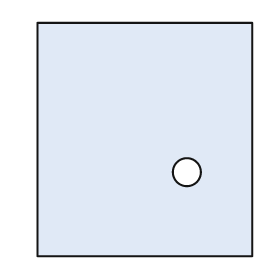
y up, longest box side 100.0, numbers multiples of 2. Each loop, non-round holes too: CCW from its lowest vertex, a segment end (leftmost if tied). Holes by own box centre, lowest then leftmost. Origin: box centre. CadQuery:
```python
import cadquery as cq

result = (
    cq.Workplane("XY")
    .moveTo(-46.0, -50.0)
    .lineTo(46.0, -50.0)
    .lineTo(46.0, 50.0)
    .lineTo(-46.0, 50.0)
    .close()
    .moveTo(18.0, -14.0)
    .circle(6.0)
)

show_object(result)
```